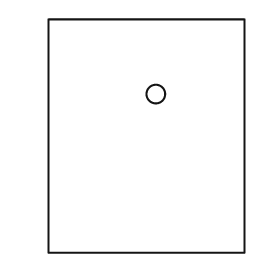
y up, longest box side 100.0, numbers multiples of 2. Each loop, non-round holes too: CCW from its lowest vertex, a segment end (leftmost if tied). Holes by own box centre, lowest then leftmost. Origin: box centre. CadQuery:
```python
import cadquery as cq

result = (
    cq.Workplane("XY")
    .moveTo(-42.0, -50.0)
    .lineTo(42.0, -50.0)
    .lineTo(42.0, 50.0)
    .lineTo(-42.0, 50.0)
    .close()
    .moveTo(4.0, 18.0)
    .circle(4.0)
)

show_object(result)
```